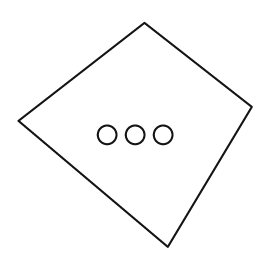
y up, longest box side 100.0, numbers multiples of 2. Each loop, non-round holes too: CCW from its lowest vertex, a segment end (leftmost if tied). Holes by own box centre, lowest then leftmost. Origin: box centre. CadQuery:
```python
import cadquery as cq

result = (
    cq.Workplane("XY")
    .moveTo(14.0, -48.0)
    .lineTo(50.0, 12.0)
    .lineTo(4.0, 48.0)
    .lineTo(-50.0, 6.0)
    .close()
    .moveTo(-12.0, 0.0)
    .circle(4.0)
    .moveTo(0.0, 0.0)
    .circle(4.0)
    .moveTo(12.0, 0.0)
    .circle(4.0)
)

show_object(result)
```